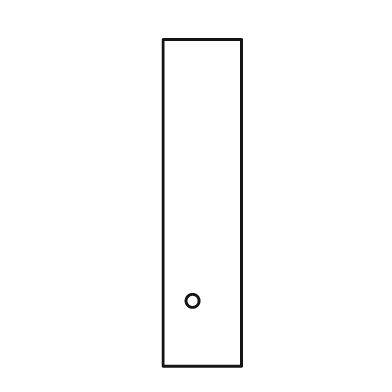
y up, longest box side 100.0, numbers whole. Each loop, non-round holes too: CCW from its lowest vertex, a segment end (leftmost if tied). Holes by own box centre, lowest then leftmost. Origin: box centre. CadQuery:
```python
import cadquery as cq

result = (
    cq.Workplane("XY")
    .moveTo(-12.0, -50.0)
    .lineTo(12.0, -50.0)
    .lineTo(12.0, 50.0)
    .lineTo(-12.0, 50.0)
    .close()
    .moveTo(-3.0, -30.0)
    .circle(2.0)
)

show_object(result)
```